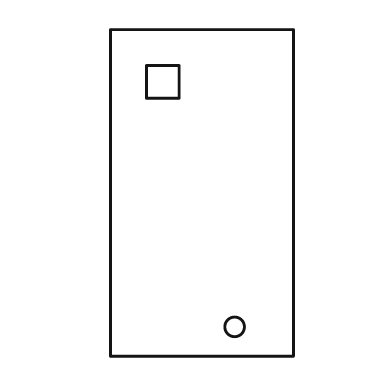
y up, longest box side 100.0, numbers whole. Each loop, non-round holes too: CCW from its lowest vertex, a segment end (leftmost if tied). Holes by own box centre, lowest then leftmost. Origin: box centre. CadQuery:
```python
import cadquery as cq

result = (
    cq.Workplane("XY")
    .moveTo(-28.0, -50.0)
    .lineTo(28.0, -50.0)
    .lineTo(28.0, 50.0)
    .lineTo(-28.0, 50.0)
    .close()
    .moveTo(10.0, -41.0)
    .circle(3.0)
    .moveTo(-17.0, 29.0)
    .lineTo(-7.0, 29.0)
    .lineTo(-7.0, 39.0)
    .lineTo(-17.0, 39.0)
    .close()
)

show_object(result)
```